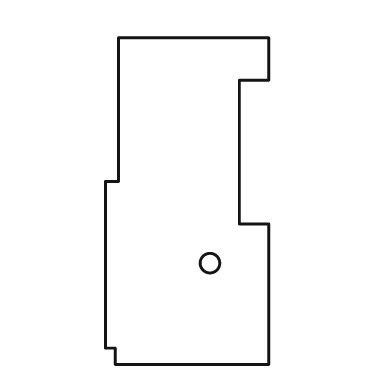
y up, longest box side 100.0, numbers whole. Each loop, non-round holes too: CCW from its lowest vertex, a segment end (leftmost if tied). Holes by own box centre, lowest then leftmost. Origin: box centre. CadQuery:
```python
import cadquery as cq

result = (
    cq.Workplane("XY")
    .moveTo(-22.0, -50.0)
    .lineTo(25.0, -50.0)
    .lineTo(25.0, -7.0)
    .lineTo(16.0, -7.0)
    .lineTo(16.0, 37.0)
    .lineTo(25.0, 37.0)
    .lineTo(25.0, 50.0)
    .lineTo(-21.0, 50.0)
    .lineTo(-21.0, 6.0)
    .lineTo(-25.0, 6.0)
    .lineTo(-25.0, -45.0)
    .lineTo(-22.0, -45.0)
    .close()
    .moveTo(7.0, -19.0)
    .circle(3.0)
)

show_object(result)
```